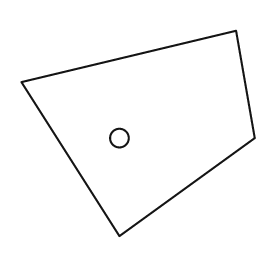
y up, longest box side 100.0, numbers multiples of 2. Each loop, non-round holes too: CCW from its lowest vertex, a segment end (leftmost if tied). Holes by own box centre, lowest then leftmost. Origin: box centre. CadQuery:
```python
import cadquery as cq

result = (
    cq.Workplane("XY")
    .moveTo(-8.0, -44.0)
    .lineTo(50.0, -2.0)
    .lineTo(42.0, 44.0)
    .lineTo(-50.0, 22.0)
    .close()
    .moveTo(-8.0, -2.0)
    .circle(4.0)
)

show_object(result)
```